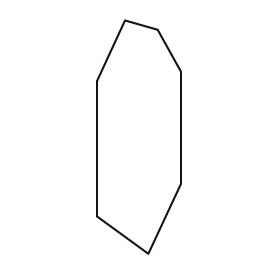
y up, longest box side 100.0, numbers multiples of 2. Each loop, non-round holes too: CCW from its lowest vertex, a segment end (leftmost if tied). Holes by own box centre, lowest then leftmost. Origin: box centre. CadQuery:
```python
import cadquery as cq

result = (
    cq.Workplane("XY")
    .moveTo(4.0, -50.0)
    .lineTo(18.0, -20.0)
    .lineTo(18.0, 28.0)
    .lineTo(8.0, 46.0)
    .lineTo(-6.0, 50.0)
    .lineTo(-18.0, 24.0)
    .lineTo(-18.0, -34.0)
    .close()
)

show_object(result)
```